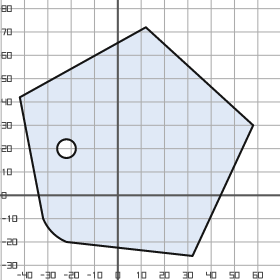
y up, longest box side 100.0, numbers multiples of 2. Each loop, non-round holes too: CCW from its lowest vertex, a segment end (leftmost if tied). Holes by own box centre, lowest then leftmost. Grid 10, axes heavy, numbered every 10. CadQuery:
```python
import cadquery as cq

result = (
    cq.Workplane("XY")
    .moveTo(32.0, -26.0)
    .lineTo(58.0, 30.0)
    .lineTo(12.0, 72.0)
    .lineTo(-42.0, 42.0)
    .lineTo(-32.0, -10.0)
    .threePointArc((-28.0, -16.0), (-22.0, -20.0))
    .close()
    .moveTo(-22.0, 20.0)
    .circle(4.0)
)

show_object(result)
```